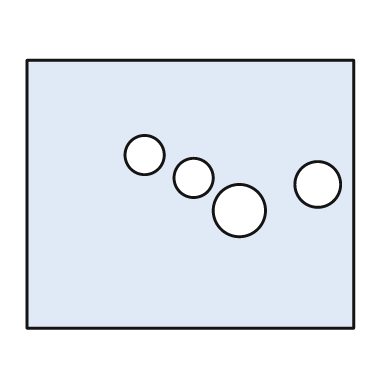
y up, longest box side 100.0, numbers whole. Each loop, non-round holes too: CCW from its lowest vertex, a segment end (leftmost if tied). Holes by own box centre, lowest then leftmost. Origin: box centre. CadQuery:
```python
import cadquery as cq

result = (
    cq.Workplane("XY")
    .moveTo(-50.0, -41.0)
    .lineTo(50.0, -41.0)
    .lineTo(50.0, 41.0)
    .lineTo(-50.0, 41.0)
    .close()
    .moveTo(15.0, -5.0)
    .circle(8.0)
    .moveTo(39.0, 3.0)
    .circle(7.0)
    .moveTo(1.0, 5.0)
    .circle(6.0)
    .moveTo(-14.0, 12.0)
    .circle(6.0)
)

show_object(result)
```